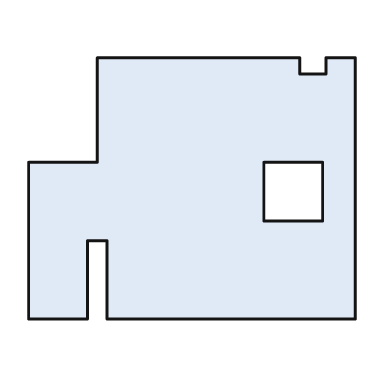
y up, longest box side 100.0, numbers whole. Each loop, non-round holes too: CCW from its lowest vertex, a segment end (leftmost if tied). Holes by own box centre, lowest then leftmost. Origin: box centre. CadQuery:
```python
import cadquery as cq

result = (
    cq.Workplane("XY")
    .moveTo(-50.0, -40.0)
    .lineTo(-32.0, -40.0)
    .lineTo(-32.0, -16.0)
    .lineTo(-26.0, -16.0)
    .lineTo(-26.0, -40.0)
    .lineTo(50.0, -40.0)
    .lineTo(50.0, 40.0)
    .lineTo(41.0, 40.0)
    .lineTo(41.0, 35.0)
    .lineTo(33.0, 35.0)
    .lineTo(33.0, 40.0)
    .lineTo(-29.0, 40.0)
    .lineTo(-29.0, 8.0)
    .lineTo(-50.0, 8.0)
    .close()
    .moveTo(22.0, -10.0)
    .lineTo(40.0, -10.0)
    .lineTo(40.0, 8.0)
    .lineTo(22.0, 8.0)
    .close()
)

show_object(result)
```